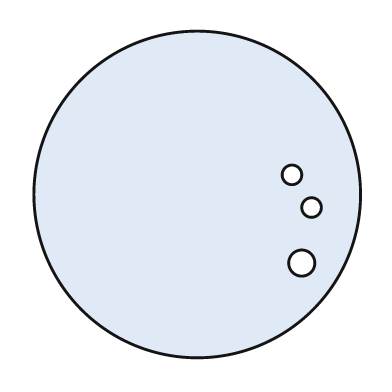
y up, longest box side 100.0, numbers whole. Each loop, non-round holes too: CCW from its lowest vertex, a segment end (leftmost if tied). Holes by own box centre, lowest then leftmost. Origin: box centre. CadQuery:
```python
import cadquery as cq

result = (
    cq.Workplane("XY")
    .moveTo(0.0, 0.0)
    .circle(50.0)
    .moveTo(32.0, -21.0)
    .circle(4.0)
    .moveTo(35.0, -4.0)
    .circle(3.0)
    .moveTo(29.0, 6.0)
    .circle(3.0)
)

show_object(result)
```